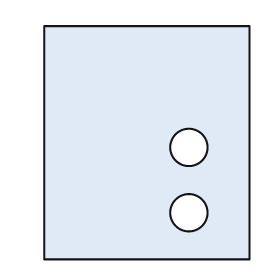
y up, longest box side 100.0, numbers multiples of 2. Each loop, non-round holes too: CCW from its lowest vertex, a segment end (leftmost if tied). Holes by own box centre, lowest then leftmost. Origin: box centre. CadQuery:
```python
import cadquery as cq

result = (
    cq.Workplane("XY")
    .moveTo(-44.0, -50.0)
    .lineTo(44.0, -50.0)
    .lineTo(44.0, 50.0)
    .lineTo(-44.0, 50.0)
    .close()
    .moveTo(18.0, -30.0)
    .circle(8.0)
    .moveTo(18.0, -2.0)
    .circle(8.0)
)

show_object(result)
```